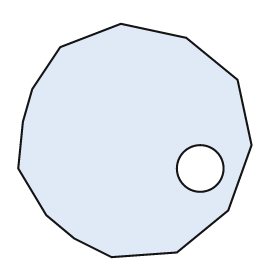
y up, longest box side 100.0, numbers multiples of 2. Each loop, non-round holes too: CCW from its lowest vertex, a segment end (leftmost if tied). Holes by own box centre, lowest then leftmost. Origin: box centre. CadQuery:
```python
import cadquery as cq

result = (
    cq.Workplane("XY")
    .moveTo(-10.0, -50.0)
    .lineTo(18.0, -48.0)
    .lineTo(40.0, -30.0)
    .lineTo(50.0, -2.0)
    .lineTo(44.0, 26.0)
    .lineTo(22.0, 44.0)
    .lineTo(-6.0, 50.0)
    .lineTo(-32.0, 40.0)
    .lineTo(-44.0, 22.0)
    .lineTo(-48.0, 8.0)
    .lineTo(-50.0, -12.0)
    .lineTo(-38.0, -32.0)
    .lineTo(-26.0, -42.0)
    .close()
    .moveTo(28.0, -12.0)
    .circle(10.0)
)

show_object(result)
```